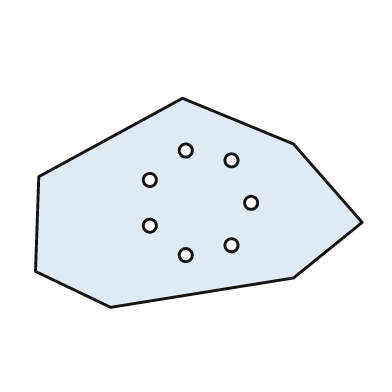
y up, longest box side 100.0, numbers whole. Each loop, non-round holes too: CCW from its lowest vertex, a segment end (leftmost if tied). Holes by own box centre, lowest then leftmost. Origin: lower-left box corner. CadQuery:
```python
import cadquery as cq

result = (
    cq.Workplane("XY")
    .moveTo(23.0, 0.0)
    .lineTo(79.0, 9.0)
    .lineTo(100.0, 26.0)
    .lineTo(79.0, 50.0)
    .lineTo(45.0, 64.0)
    .lineTo(1.0, 40.0)
    .lineTo(0.0, 11.0)
    .close()
    .moveTo(46.0, 16.0)
    .circle(2.0)
    .moveTo(60.0, 19.0)
    .circle(2.0)
    .moveTo(35.0, 25.0)
    .circle(2.0)
    .moveTo(66.0, 32.0)
    .circle(2.0)
    .moveTo(35.0, 39.0)
    .circle(2.0)
    .moveTo(60.0, 45.0)
    .circle(2.0)
    .moveTo(46.0, 48.0)
    .circle(2.0)
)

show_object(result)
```